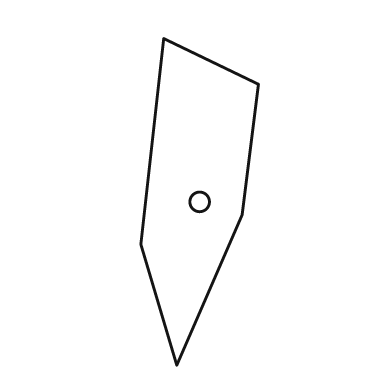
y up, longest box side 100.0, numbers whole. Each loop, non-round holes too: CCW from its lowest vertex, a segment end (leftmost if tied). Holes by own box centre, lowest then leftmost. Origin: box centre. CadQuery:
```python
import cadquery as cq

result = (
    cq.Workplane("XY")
    .moveTo(-7.0, -50.0)
    .lineTo(13.0, -4.0)
    .lineTo(18.0, 36.0)
    .lineTo(-11.0, 50.0)
    .lineTo(-18.0, -13.0)
    .close()
    .moveTo(0.0, 0.0)
    .circle(3.0)
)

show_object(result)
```